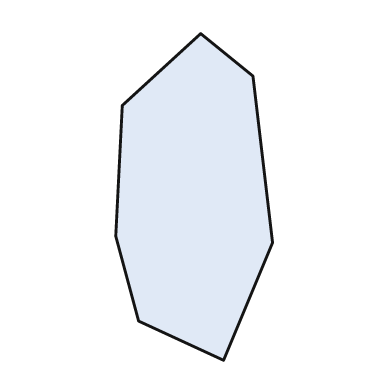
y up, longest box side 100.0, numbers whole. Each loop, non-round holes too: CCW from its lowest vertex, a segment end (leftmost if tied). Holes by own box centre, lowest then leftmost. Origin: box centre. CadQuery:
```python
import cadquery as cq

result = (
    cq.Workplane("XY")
    .moveTo(9.0, -50.0)
    .lineTo(24.0, -14.0)
    .lineTo(18.0, 37.0)
    .lineTo(2.0, 50.0)
    .lineTo(-22.0, 28.0)
    .lineTo(-24.0, -12.0)
    .lineTo(-17.0, -38.0)
    .close()
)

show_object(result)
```